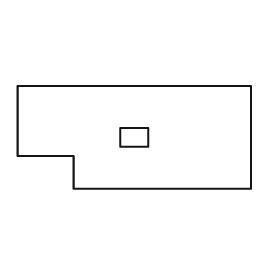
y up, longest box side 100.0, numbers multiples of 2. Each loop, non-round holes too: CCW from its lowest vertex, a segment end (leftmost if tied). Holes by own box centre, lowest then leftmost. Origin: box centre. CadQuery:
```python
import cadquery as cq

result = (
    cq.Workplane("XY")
    .moveTo(-26.0, -22.0)
    .lineTo(50.0, -22.0)
    .lineTo(50.0, 22.0)
    .lineTo(-50.0, 22.0)
    .lineTo(-50.0, -8.0)
    .lineTo(-26.0, -8.0)
    .close()
    .moveTo(-6.0, -4.0)
    .lineTo(6.0, -4.0)
    .lineTo(6.0, 4.0)
    .lineTo(-6.0, 4.0)
    .close()
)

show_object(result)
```